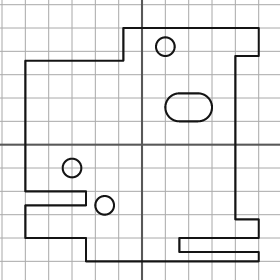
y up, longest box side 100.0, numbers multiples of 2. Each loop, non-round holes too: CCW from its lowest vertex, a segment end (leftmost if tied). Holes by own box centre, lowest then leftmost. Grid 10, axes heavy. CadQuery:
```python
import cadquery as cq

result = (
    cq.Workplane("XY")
    .moveTo(-24.0, -50.0)
    .lineTo(50.0, -50.0)
    .lineTo(50.0, -46.0)
    .lineTo(16.0, -46.0)
    .lineTo(16.0, -40.0)
    .lineTo(50.0, -40.0)
    .lineTo(50.0, -32.0)
    .lineTo(40.0, -32.0)
    .lineTo(40.0, 38.0)
    .lineTo(50.0, 38.0)
    .lineTo(50.0, 50.0)
    .lineTo(-8.0, 50.0)
    .lineTo(-8.0, 36.0)
    .lineTo(-50.0, 36.0)
    .lineTo(-50.0, -20.0)
    .lineTo(-24.0, -20.0)
    .lineTo(-24.0, -26.0)
    .lineTo(-50.0, -26.0)
    .lineTo(-50.0, -40.0)
    .lineTo(-24.0, -40.0)
    .close()
    .moveTo(-16.0, -26.0)
    .circle(4.0)
    .moveTo(-30.0, -10.0)
    .circle(4.0)
    .moveTo(16.0, 10.0)
    .lineTo(24.0, 10.0)
    .threePointArc((30.0, 16.0), (24.0, 22.0))
    .lineTo(16.0, 22.0)
    .threePointArc((10.0, 16.0), (16.0, 10.0))
    .close()
    .moveTo(10.0, 42.0)
    .circle(4.0)
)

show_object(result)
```